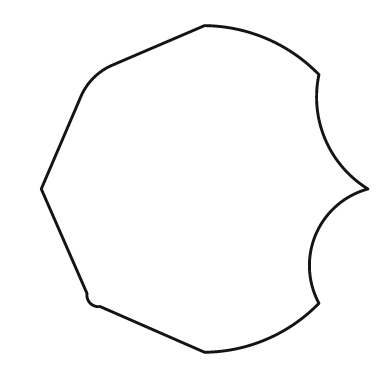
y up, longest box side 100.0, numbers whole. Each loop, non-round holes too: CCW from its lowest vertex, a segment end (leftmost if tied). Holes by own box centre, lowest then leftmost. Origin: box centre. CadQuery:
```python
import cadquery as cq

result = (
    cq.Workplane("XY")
    .moveTo(0.0, -50.0)
    .threePointArc((19.0, -46.0), (35.0, -35.0))
    .threePointArc((34.0, -14.0), (50.0, 0.0))
    .threePointArc((37.0, 15.0), (35.0, 35.0))
    .threePointArc((19.0, 46.0), (0.0, 50.0))
    .lineTo(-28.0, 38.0)
    .threePointArc((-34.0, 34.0), (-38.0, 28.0))
    .lineTo(-50.0, 0.0)
    .lineTo(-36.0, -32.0)
    .threePointArc((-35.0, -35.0), (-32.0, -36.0))
    .close()
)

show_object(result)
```